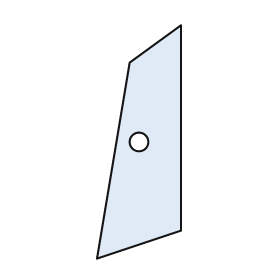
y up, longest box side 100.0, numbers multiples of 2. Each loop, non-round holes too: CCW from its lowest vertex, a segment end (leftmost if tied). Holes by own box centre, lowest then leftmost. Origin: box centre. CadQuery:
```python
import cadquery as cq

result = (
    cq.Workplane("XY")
    .moveTo(-18.0, -50.0)
    .lineTo(18.0, -38.0)
    .lineTo(18.0, 50.0)
    .lineTo(-4.0, 34.0)
    .close()
    .moveTo(0.0, 0.0)
    .circle(4.0)
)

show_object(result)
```